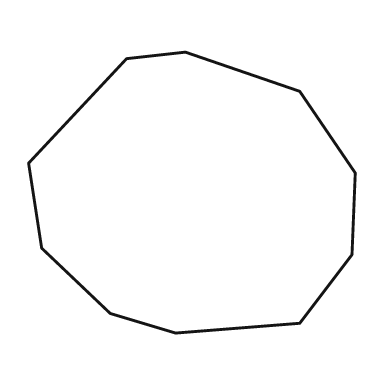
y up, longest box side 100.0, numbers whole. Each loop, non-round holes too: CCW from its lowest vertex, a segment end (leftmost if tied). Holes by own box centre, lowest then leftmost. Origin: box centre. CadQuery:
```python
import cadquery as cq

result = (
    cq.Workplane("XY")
    .moveTo(-5.0, -43.0)
    .lineTo(33.0, -40.0)
    .lineTo(49.0, -19.0)
    .lineTo(50.0, 6.0)
    .lineTo(33.0, 31.0)
    .lineTo(-2.0, 43.0)
    .lineTo(-20.0, 41.0)
    .lineTo(-50.0, 9.0)
    .lineTo(-46.0, -17.0)
    .lineTo(-25.0, -37.0)
    .close()
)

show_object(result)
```